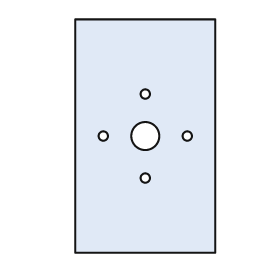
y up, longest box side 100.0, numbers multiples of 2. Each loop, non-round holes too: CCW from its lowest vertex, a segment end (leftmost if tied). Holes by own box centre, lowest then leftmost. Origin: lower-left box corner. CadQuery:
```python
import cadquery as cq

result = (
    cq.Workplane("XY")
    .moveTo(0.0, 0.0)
    .lineTo(60.0, 0.0)
    .lineTo(60.0, 100.0)
    .lineTo(0.0, 100.0)
    .close()
    .moveTo(30.0, 32.0)
    .circle(2.0)
    .moveTo(12.0, 50.0)
    .circle(2.0)
    .moveTo(30.0, 50.0)
    .circle(6.0)
    .moveTo(48.0, 50.0)
    .circle(2.0)
    .moveTo(30.0, 68.0)
    .circle(2.0)
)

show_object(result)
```